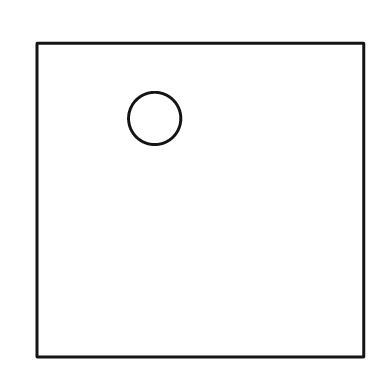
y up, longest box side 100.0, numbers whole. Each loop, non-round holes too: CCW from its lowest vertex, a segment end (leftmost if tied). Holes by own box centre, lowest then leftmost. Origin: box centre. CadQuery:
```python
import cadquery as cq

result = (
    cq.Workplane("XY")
    .moveTo(-50.0, -48.0)
    .lineTo(50.0, -48.0)
    .lineTo(50.0, 48.0)
    .lineTo(-50.0, 48.0)
    .close()
    .moveTo(-14.0, 25.0)
    .circle(8.0)
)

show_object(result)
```